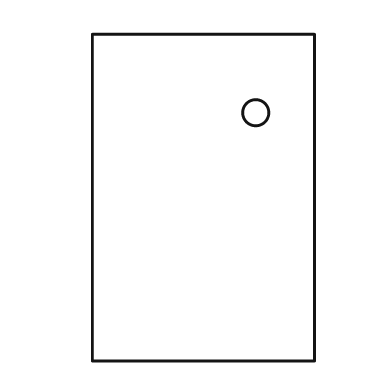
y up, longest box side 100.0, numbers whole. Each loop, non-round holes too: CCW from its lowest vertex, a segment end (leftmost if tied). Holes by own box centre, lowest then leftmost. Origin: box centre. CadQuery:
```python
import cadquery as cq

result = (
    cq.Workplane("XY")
    .moveTo(-34.0, -50.0)
    .lineTo(34.0, -50.0)
    .lineTo(34.0, 50.0)
    .lineTo(-34.0, 50.0)
    .close()
    .moveTo(16.0, 26.0)
    .circle(4.0)
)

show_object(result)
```